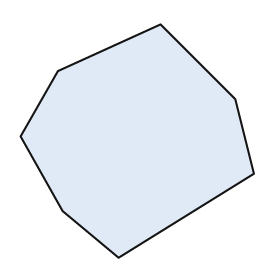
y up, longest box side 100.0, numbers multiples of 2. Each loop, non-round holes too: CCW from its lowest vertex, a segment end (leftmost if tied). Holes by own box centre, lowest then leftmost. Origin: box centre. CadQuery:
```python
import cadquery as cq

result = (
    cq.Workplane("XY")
    .moveTo(-8.0, -50.0)
    .lineTo(50.0, -14.0)
    .lineTo(42.0, 18.0)
    .lineTo(10.0, 50.0)
    .lineTo(-34.0, 30.0)
    .lineTo(-50.0, 2.0)
    .lineTo(-32.0, -30.0)
    .close()
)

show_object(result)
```